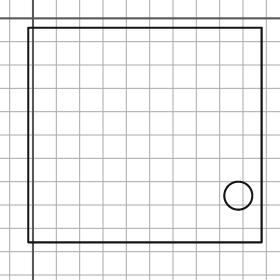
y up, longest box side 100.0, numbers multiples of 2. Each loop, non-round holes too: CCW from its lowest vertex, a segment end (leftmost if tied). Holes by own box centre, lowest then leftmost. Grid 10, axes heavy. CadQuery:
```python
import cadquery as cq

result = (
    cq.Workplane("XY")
    .moveTo(-2.0, -96.0)
    .lineTo(98.0, -96.0)
    .lineTo(98.0, -4.0)
    .lineTo(-2.0, -4.0)
    .close()
    .moveTo(88.0, -76.0)
    .circle(6.0)
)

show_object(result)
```